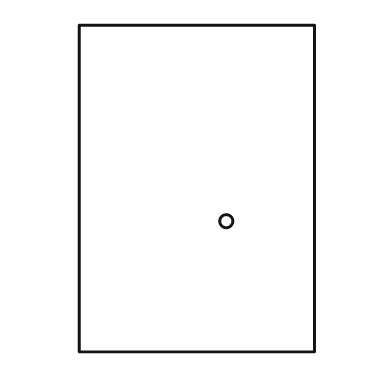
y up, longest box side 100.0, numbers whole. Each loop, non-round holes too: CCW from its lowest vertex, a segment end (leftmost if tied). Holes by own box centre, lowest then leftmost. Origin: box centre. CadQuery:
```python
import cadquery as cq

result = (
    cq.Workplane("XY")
    .moveTo(-36.0, -50.0)
    .lineTo(36.0, -50.0)
    .lineTo(36.0, 50.0)
    .lineTo(-36.0, 50.0)
    .close()
    .moveTo(9.0, -10.0)
    .circle(2.0)
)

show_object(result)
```